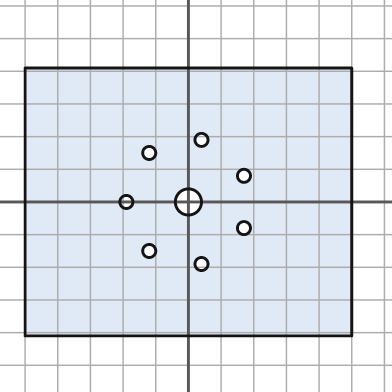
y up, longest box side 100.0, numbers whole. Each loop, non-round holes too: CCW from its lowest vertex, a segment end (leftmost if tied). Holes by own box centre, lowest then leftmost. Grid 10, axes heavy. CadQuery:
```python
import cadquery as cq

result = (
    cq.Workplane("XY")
    .moveTo(-50.0, -41.0)
    .lineTo(50.0, -41.0)
    .lineTo(50.0, 41.0)
    .lineTo(-50.0, 41.0)
    .close()
    .moveTo(4.0, -19.0)
    .circle(2.0)
    .moveTo(-12.0, -15.0)
    .circle(2.0)
    .moveTo(17.0, -8.0)
    .circle(2.0)
    .moveTo(-19.0, 0.0)
    .circle(2.0)
    .moveTo(0.0, 0.0)
    .circle(4.0)
    .moveTo(17.0, 8.0)
    .circle(2.0)
    .moveTo(-12.0, 15.0)
    .circle(2.0)
    .moveTo(4.0, 19.0)
    .circle(2.0)
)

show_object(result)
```